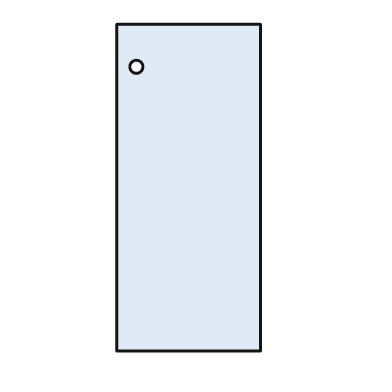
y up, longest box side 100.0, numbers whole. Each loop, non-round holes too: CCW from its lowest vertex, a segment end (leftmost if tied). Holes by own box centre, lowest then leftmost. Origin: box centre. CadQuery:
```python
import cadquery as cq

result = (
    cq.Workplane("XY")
    .moveTo(-22.0, -50.0)
    .lineTo(22.0, -50.0)
    .lineTo(22.0, 50.0)
    .lineTo(-22.0, 50.0)
    .close()
    .moveTo(-16.0, 37.0)
    .circle(2.0)
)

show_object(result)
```